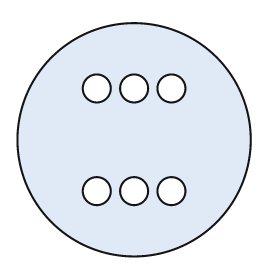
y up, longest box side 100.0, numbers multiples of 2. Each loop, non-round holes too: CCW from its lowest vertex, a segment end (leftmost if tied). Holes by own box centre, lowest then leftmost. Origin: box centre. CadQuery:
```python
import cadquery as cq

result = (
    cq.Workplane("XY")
    .moveTo(0.0, 0.0)
    .circle(50.0)
    .moveTo(-16.0, -22.0)
    .circle(6.0)
    .moveTo(0.0, -22.0)
    .circle(6.0)
    .moveTo(16.0, -22.0)
    .circle(6.0)
    .moveTo(-16.0, 22.0)
    .circle(6.0)
    .moveTo(0.0, 22.0)
    .circle(6.0)
    .moveTo(16.0, 22.0)
    .circle(6.0)
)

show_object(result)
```